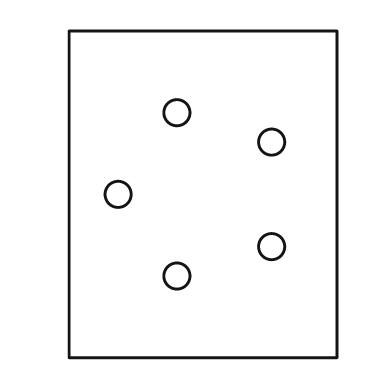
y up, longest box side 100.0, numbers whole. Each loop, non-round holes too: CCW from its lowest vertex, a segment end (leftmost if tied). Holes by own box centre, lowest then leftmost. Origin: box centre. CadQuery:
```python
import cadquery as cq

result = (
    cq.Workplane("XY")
    .moveTo(-41.0, -50.0)
    .lineTo(41.0, -50.0)
    .lineTo(41.0, 50.0)
    .lineTo(-41.0, 50.0)
    .close()
    .moveTo(-8.0, -25.0)
    .circle(4.0)
    .moveTo(21.0, -16.0)
    .circle(4.0)
    .moveTo(-26.0, 0.0)
    .circle(4.0)
    .moveTo(21.0, 16.0)
    .circle(4.0)
    .moveTo(-8.0, 25.0)
    .circle(4.0)
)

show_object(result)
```